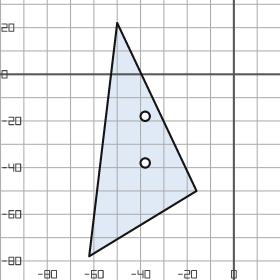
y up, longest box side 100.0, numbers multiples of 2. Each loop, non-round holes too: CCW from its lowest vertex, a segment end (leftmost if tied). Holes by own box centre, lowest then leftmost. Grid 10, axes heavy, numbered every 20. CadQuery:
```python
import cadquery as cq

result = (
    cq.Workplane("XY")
    .moveTo(-62.0, -78.0)
    .lineTo(-16.0, -50.0)
    .lineTo(-50.0, 22.0)
    .close()
    .moveTo(-38.0, -38.0)
    .circle(2.0)
    .moveTo(-38.0, -18.0)
    .circle(2.0)
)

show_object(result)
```